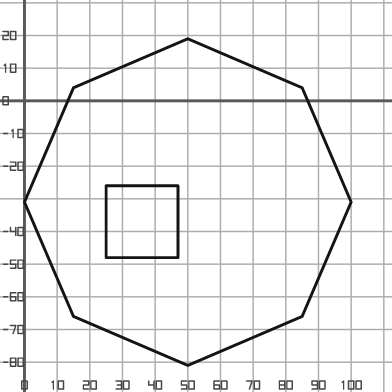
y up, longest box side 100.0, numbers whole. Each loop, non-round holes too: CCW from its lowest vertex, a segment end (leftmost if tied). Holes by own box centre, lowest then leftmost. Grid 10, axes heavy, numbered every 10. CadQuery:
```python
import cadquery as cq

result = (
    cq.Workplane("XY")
    .moveTo(50.0, -81.0)
    .lineTo(85.0, -66.0)
    .lineTo(100.0, -31.0)
    .lineTo(85.0, 4.0)
    .lineTo(50.0, 19.0)
    .lineTo(15.0, 4.0)
    .lineTo(0.0, -31.0)
    .lineTo(15.0, -66.0)
    .close()
    .moveTo(25.0, -48.0)
    .lineTo(47.0, -48.0)
    .lineTo(47.0, -26.0)
    .lineTo(25.0, -26.0)
    .close()
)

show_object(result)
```